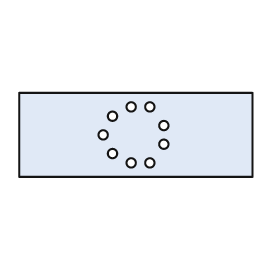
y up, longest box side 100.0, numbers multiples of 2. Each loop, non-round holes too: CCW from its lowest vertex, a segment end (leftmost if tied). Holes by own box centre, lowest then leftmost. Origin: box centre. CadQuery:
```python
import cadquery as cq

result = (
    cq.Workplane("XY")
    .moveTo(-50.0, -18.0)
    .lineTo(50.0, -18.0)
    .lineTo(50.0, 18.0)
    .lineTo(-50.0, 18.0)
    .close()
    .moveTo(-2.0, -12.0)
    .circle(2.0)
    .moveTo(6.0, -12.0)
    .circle(2.0)
    .moveTo(-10.0, -8.0)
    .circle(2.0)
    .moveTo(12.0, -4.0)
    .circle(2.0)
    .moveTo(-14.0, 0.0)
    .circle(2.0)
    .moveTo(12.0, 4.0)
    .circle(2.0)
    .moveTo(-10.0, 8.0)
    .circle(2.0)
    .moveTo(-2.0, 12.0)
    .circle(2.0)
    .moveTo(6.0, 12.0)
    .circle(2.0)
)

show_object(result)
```